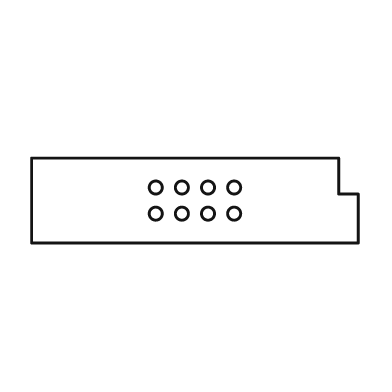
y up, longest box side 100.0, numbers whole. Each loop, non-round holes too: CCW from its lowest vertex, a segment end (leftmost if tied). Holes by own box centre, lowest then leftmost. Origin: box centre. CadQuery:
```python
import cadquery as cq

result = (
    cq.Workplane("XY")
    .moveTo(-50.0, -13.0)
    .lineTo(50.0, -13.0)
    .lineTo(50.0, 2.0)
    .lineTo(44.0, 2.0)
    .lineTo(44.0, 13.0)
    .lineTo(-50.0, 13.0)
    .close()
    .moveTo(-12.0, -4.0)
    .circle(2.0)
    .moveTo(-4.0, -4.0)
    .circle(2.0)
    .moveTo(4.0, -4.0)
    .circle(2.0)
    .moveTo(12.0, -4.0)
    .circle(2.0)
    .moveTo(-12.0, 4.0)
    .circle(2.0)
    .moveTo(-4.0, 4.0)
    .circle(2.0)
    .moveTo(4.0, 4.0)
    .circle(2.0)
    .moveTo(12.0, 4.0)
    .circle(2.0)
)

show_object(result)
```